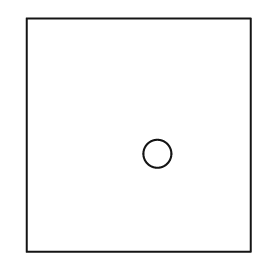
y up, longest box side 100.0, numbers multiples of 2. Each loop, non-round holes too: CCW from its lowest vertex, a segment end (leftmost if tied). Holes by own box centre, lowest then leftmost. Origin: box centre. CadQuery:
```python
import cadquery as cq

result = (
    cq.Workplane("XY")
    .moveTo(-48.0, -50.0)
    .lineTo(48.0, -50.0)
    .lineTo(48.0, 50.0)
    .lineTo(-48.0, 50.0)
    .close()
    .moveTo(8.0, -8.0)
    .circle(6.0)
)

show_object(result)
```